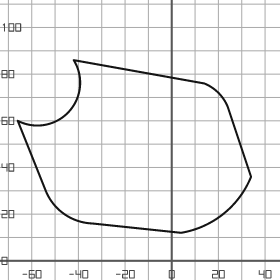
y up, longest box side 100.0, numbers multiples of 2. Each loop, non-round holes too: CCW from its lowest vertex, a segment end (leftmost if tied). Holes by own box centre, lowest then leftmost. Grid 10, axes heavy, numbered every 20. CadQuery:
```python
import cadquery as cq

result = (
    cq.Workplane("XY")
    .moveTo(4.0, 12.0)
    .threePointArc((22.0, 20.0), (34.0, 36.0))
    .lineTo(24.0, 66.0)
    .threePointArc((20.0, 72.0), (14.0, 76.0))
    .lineTo(-42.0, 86.0)
    .threePointArc((-44.0, 64.0), (-66.0, 60.0))
    .lineTo(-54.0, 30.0)
    .threePointArc((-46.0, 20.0), (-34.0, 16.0))
    .close()
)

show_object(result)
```